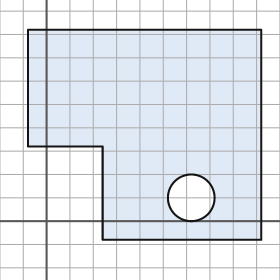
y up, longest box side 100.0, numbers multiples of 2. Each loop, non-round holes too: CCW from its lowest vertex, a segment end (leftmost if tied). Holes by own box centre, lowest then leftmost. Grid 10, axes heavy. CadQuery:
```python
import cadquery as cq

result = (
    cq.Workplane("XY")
    .moveTo(24.0, -8.0)
    .lineTo(92.0, -8.0)
    .lineTo(92.0, 82.0)
    .lineTo(-8.0, 82.0)
    .lineTo(-8.0, 32.0)
    .lineTo(24.0, 32.0)
    .close()
    .moveTo(62.0, 10.0)
    .circle(10.0)
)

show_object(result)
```